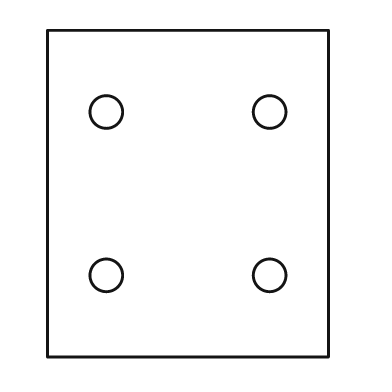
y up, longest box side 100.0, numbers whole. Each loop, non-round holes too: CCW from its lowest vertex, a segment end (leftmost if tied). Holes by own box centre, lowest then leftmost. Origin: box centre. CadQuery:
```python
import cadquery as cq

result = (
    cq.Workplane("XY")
    .moveTo(-43.0, -50.0)
    .lineTo(43.0, -50.0)
    .lineTo(43.0, 50.0)
    .lineTo(-43.0, 50.0)
    .close()
    .moveTo(-25.0, -25.0)
    .circle(5.0)
    .moveTo(25.0, -25.0)
    .circle(5.0)
    .moveTo(-25.0, 25.0)
    .circle(5.0)
    .moveTo(25.0, 25.0)
    .circle(5.0)
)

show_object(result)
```